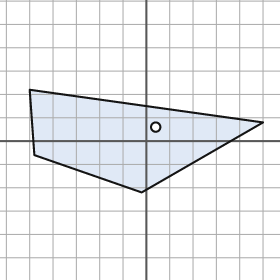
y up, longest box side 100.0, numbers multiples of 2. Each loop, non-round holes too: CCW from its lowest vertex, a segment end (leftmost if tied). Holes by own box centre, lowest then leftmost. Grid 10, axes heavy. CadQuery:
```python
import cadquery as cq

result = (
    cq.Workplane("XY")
    .moveTo(-2.0, -22.0)
    .lineTo(50.0, 8.0)
    .lineTo(-50.0, 22.0)
    .lineTo(-48.0, -6.0)
    .close()
    .moveTo(4.0, 6.0)
    .circle(2.0)
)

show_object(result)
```